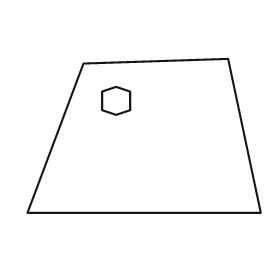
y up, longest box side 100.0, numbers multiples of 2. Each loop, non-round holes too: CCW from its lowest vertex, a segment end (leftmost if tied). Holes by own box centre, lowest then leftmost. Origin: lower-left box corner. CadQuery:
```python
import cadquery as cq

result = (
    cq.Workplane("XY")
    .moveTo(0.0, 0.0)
    .lineTo(100.0, 0.0)
    .lineTo(86.0, 66.0)
    .lineTo(24.0, 64.0)
    .close()
    .moveTo(38.0, 42.0)
    .lineTo(44.0, 44.0)
    .lineTo(44.0, 52.0)
    .lineTo(38.0, 54.0)
    .lineTo(32.0, 52.0)
    .lineTo(32.0, 44.0)
    .close()
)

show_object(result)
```